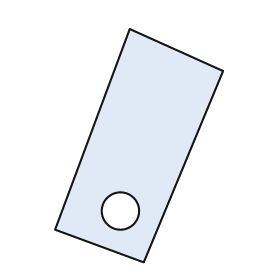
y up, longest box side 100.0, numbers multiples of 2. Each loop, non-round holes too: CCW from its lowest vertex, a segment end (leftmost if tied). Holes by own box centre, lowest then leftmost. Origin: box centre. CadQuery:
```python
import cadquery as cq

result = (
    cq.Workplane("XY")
    .moveTo(2.0, -50.0)
    .lineTo(36.0, 32.0)
    .lineTo(-4.0, 50.0)
    .lineTo(-36.0, -36.0)
    .close()
    .moveTo(-8.0, -28.0)
    .circle(8.0)
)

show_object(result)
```